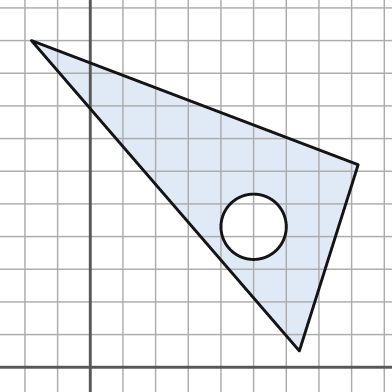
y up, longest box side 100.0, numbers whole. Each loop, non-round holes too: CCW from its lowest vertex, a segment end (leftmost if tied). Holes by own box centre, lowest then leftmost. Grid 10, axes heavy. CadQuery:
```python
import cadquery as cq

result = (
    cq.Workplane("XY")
    .moveTo(64.0, 5.0)
    .lineTo(82.0, 62.0)
    .lineTo(-18.0, 100.0)
    .close()
    .moveTo(50.0, 43.0)
    .circle(10.0)
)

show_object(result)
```